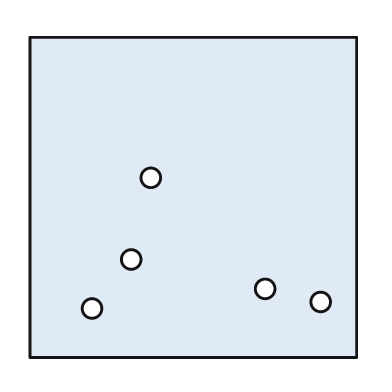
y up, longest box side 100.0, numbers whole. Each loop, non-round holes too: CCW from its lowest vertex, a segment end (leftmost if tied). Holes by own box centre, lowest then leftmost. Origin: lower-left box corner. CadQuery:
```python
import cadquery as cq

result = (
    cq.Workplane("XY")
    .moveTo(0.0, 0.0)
    .lineTo(100.0, 0.0)
    .lineTo(100.0, 98.0)
    .lineTo(0.0, 98.0)
    .close()
    .moveTo(19.0, 15.0)
    .circle(3.0)
    .moveTo(89.0, 17.0)
    .circle(3.0)
    .moveTo(72.0, 21.0)
    .circle(3.0)
    .moveTo(31.0, 30.0)
    .circle(3.0)
    .moveTo(37.0, 55.0)
    .circle(3.0)
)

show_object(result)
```